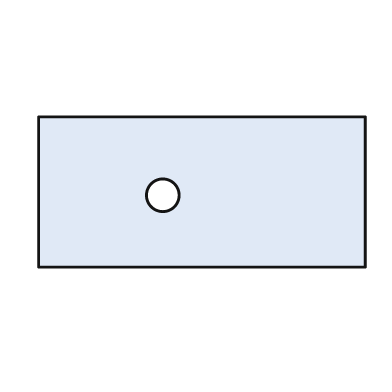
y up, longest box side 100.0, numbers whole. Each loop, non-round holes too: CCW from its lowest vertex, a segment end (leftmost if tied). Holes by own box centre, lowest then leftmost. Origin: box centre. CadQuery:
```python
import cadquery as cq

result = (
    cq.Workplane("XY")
    .moveTo(-50.0, -23.0)
    .lineTo(50.0, -23.0)
    .lineTo(50.0, 23.0)
    .lineTo(-50.0, 23.0)
    .close()
    .moveTo(-12.0, -1.0)
    .circle(5.0)
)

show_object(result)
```